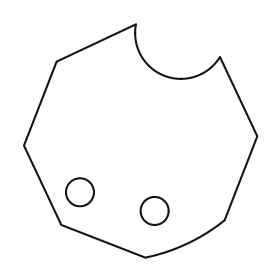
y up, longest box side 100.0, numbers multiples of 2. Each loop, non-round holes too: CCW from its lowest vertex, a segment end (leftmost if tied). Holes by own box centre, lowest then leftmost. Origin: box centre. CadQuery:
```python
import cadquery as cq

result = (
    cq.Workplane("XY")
    .moveTo(2.0, -50.0)
    .threePointArc((20.0, -44.0), (36.0, -34.0))
    .lineTo(50.0, 2.0)
    .lineTo(34.0, 36.0)
    .threePointArc((10.0, 28.0), (-2.0, 50.0))
    .lineTo(-36.0, 34.0)
    .lineTo(-50.0, -2.0)
    .lineTo(-34.0, -36.0)
    .close()
    .moveTo(6.0, -30.0)
    .circle(6.0)
    .moveTo(-26.0, -22.0)
    .circle(6.0)
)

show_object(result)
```